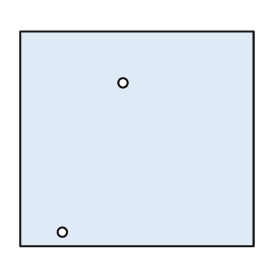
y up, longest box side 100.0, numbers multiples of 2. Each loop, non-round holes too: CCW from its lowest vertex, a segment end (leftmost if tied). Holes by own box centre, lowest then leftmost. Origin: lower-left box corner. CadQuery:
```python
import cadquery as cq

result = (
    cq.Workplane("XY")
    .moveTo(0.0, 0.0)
    .lineTo(100.0, 0.0)
    .lineTo(100.0, 92.0)
    .lineTo(0.0, 92.0)
    .close()
    .moveTo(18.0, 6.0)
    .circle(2.0)
    .moveTo(44.0, 70.0)
    .circle(2.0)
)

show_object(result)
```